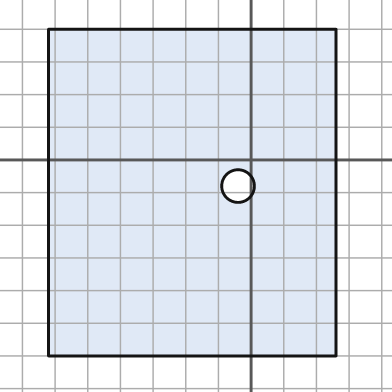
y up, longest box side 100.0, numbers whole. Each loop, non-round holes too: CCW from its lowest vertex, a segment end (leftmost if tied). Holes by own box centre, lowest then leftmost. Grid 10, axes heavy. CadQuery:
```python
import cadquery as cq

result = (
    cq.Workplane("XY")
    .moveTo(-62.0, -60.0)
    .lineTo(26.0, -60.0)
    .lineTo(26.0, 40.0)
    .lineTo(-62.0, 40.0)
    .close()
    .moveTo(-4.0, -8.0)
    .circle(5.0)
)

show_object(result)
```